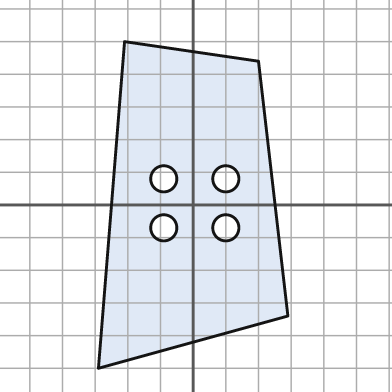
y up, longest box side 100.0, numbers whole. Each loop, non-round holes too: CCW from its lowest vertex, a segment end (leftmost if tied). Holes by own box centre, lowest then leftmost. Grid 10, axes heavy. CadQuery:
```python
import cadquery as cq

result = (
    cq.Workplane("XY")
    .moveTo(-29.0, -50.0)
    .lineTo(29.0, -34.0)
    .lineTo(20.0, 44.0)
    .lineTo(-21.0, 50.0)
    .close()
    .moveTo(-9.0, -7.0)
    .circle(4.0)
    .moveTo(10.0, -7.0)
    .circle(4.0)
    .moveTo(-9.0, 8.0)
    .circle(4.0)
    .moveTo(10.0, 8.0)
    .circle(4.0)
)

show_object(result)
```